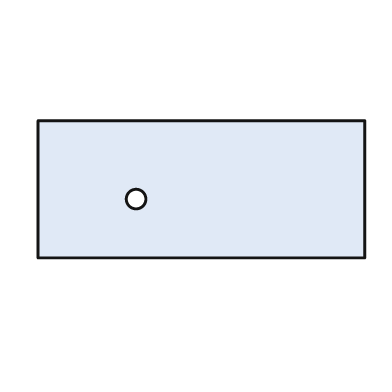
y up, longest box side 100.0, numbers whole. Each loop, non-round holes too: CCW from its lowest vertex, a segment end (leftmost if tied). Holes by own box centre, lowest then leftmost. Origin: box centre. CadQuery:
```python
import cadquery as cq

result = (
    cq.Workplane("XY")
    .moveTo(-50.0, -21.0)
    .lineTo(50.0, -21.0)
    .lineTo(50.0, 21.0)
    .lineTo(-50.0, 21.0)
    .close()
    .moveTo(-20.0, -3.0)
    .circle(3.0)
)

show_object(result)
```